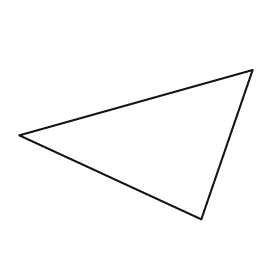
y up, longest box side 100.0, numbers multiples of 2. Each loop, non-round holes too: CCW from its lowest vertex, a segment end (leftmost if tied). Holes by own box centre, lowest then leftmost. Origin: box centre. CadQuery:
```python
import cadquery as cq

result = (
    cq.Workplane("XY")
    .moveTo(28.0, -32.0)
    .lineTo(50.0, 32.0)
    .lineTo(-50.0, 4.0)
    .close()
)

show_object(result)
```